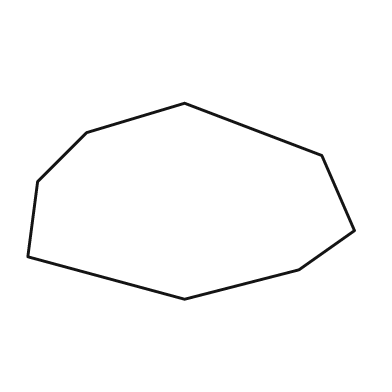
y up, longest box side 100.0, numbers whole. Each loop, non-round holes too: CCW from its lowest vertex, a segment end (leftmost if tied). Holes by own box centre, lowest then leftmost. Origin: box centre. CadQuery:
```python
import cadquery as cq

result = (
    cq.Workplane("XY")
    .moveTo(-2.0, -30.0)
    .lineTo(33.0, -21.0)
    .lineTo(50.0, -9.0)
    .lineTo(40.0, 14.0)
    .lineTo(-2.0, 30.0)
    .lineTo(-32.0, 21.0)
    .lineTo(-47.0, 6.0)
    .lineTo(-50.0, -17.0)
    .close()
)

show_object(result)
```